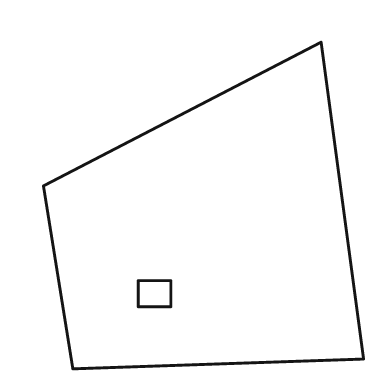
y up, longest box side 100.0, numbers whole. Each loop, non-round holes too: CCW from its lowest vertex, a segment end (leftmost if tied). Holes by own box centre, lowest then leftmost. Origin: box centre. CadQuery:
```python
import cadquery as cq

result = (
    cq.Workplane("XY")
    .moveTo(-40.0, -50.0)
    .lineTo(49.0, -47.0)
    .lineTo(36.0, 50.0)
    .lineTo(-49.0, 6.0)
    .close()
    .moveTo(-20.0, -31.0)
    .lineTo(-10.0, -31.0)
    .lineTo(-10.0, -23.0)
    .lineTo(-20.0, -23.0)
    .close()
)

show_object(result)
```